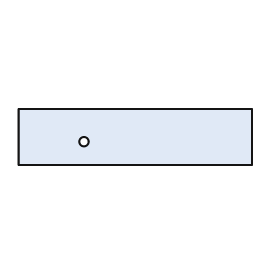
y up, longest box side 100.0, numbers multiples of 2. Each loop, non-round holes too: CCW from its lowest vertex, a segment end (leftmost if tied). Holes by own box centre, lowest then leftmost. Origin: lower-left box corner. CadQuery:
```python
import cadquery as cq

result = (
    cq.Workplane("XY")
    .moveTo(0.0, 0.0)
    .lineTo(100.0, 0.0)
    .lineTo(100.0, 24.0)
    .lineTo(0.0, 24.0)
    .close()
    .moveTo(28.0, 10.0)
    .circle(2.0)
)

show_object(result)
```